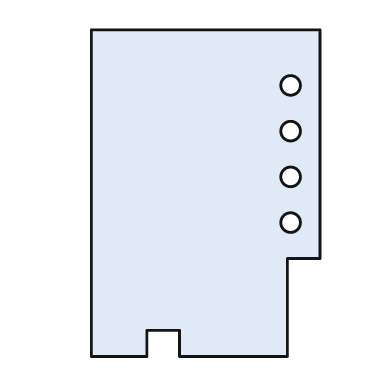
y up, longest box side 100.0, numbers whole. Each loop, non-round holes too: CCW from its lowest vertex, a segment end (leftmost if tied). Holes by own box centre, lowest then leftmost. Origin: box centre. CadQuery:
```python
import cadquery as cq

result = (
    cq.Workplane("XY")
    .moveTo(-35.0, -50.0)
    .lineTo(-18.0, -50.0)
    .lineTo(-18.0, -42.0)
    .lineTo(-8.0, -42.0)
    .lineTo(-8.0, -50.0)
    .lineTo(25.0, -50.0)
    .lineTo(25.0, -20.0)
    .lineTo(35.0, -20.0)
    .lineTo(35.0, 50.0)
    .lineTo(-35.0, 50.0)
    .close()
    .moveTo(26.0, -9.0)
    .circle(3.0)
    .moveTo(26.0, 5.0)
    .circle(3.0)
    .moveTo(26.0, 19.0)
    .circle(3.0)
    .moveTo(26.0, 33.0)
    .circle(3.0)
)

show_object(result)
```